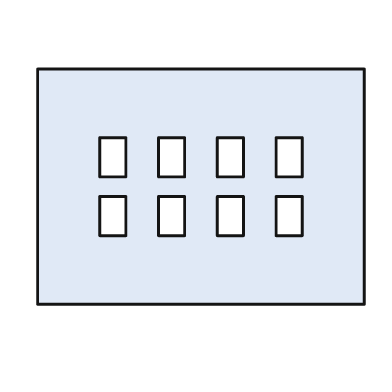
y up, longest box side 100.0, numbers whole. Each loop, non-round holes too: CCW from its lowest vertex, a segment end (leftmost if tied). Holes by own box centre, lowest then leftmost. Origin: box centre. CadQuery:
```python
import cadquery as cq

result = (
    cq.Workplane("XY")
    .moveTo(-50.0, -36.0)
    .lineTo(50.0, -36.0)
    .lineTo(50.0, 36.0)
    .lineTo(-50.0, 36.0)
    .close()
    .moveTo(-31.0, -15.0)
    .lineTo(-23.0, -15.0)
    .lineTo(-23.0, -3.0)
    .lineTo(-31.0, -3.0)
    .close()
    .moveTo(-13.0, -15.0)
    .lineTo(-5.0, -15.0)
    .lineTo(-5.0, -3.0)
    .lineTo(-13.0, -3.0)
    .close()
    .moveTo(5.0, -15.0)
    .lineTo(13.0, -15.0)
    .lineTo(13.0, -3.0)
    .lineTo(5.0, -3.0)
    .close()
    .moveTo(23.0, -15.0)
    .lineTo(31.0, -15.0)
    .lineTo(31.0, -3.0)
    .lineTo(23.0, -3.0)
    .close()
    .moveTo(-31.0, 3.0)
    .lineTo(-23.0, 3.0)
    .lineTo(-23.0, 15.0)
    .lineTo(-31.0, 15.0)
    .close()
    .moveTo(-13.0, 3.0)
    .lineTo(-5.0, 3.0)
    .lineTo(-5.0, 15.0)
    .lineTo(-13.0, 15.0)
    .close()
    .moveTo(5.0, 3.0)
    .lineTo(13.0, 3.0)
    .lineTo(13.0, 15.0)
    .lineTo(5.0, 15.0)
    .close()
    .moveTo(23.0, 3.0)
    .lineTo(31.0, 3.0)
    .lineTo(31.0, 15.0)
    .lineTo(23.0, 15.0)
    .close()
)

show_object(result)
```